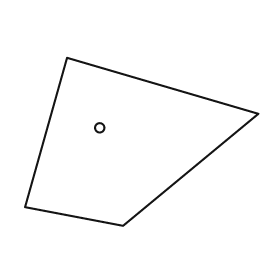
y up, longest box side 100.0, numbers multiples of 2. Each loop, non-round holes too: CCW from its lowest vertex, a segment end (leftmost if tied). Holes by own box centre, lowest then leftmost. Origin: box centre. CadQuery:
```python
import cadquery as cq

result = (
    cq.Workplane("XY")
    .moveTo(-8.0, -36.0)
    .lineTo(50.0, 12.0)
    .lineTo(-32.0, 36.0)
    .lineTo(-50.0, -28.0)
    .close()
    .moveTo(-18.0, 6.0)
    .circle(2.0)
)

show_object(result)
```